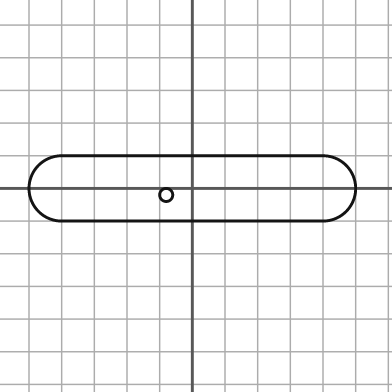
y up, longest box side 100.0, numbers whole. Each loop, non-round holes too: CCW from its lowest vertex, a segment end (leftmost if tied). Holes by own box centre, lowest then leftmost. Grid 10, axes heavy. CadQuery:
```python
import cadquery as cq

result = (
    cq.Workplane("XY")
    .moveTo(-40.0, -10.0)
    .lineTo(40.0, -10.0)
    .threePointArc((50.0, 0.0), (40.0, 10.0))
    .lineTo(-40.0, 10.0)
    .threePointArc((-50.0, 0.0), (-40.0, -10.0))
    .close()
    .moveTo(-8.0, -2.0)
    .circle(2.0)
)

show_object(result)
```